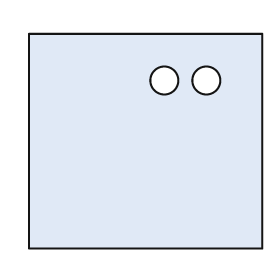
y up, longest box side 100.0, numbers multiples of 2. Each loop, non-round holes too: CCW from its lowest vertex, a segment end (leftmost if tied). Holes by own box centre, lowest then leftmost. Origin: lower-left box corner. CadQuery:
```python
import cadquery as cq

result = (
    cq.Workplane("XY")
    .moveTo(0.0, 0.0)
    .lineTo(100.0, 0.0)
    .lineTo(100.0, 92.0)
    .lineTo(0.0, 92.0)
    .close()
    .moveTo(58.0, 72.0)
    .circle(6.0)
    .moveTo(76.0, 72.0)
    .circle(6.0)
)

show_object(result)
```